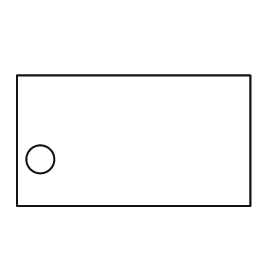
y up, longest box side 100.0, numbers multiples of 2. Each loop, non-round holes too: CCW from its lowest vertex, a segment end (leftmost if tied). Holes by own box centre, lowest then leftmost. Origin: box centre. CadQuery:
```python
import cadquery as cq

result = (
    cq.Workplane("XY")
    .moveTo(-50.0, -28.0)
    .lineTo(50.0, -28.0)
    .lineTo(50.0, 28.0)
    .lineTo(-50.0, 28.0)
    .close()
    .moveTo(-40.0, -8.0)
    .circle(6.0)
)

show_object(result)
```